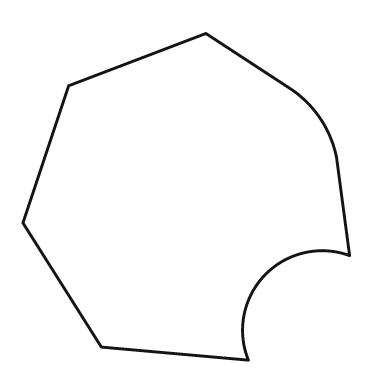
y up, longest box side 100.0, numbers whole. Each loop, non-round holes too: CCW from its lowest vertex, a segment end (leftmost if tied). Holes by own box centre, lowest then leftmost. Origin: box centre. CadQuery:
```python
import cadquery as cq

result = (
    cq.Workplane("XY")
    .moveTo(19.0, -50.0)
    .threePointArc((24.0, -24.0), (50.0, -18.0))
    .lineTo(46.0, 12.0)
    .threePointArc((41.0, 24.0), (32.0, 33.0))
    .lineTo(6.0, 50.0)
    .lineTo(-36.0, 34.0)
    .lineTo(-50.0, -8.0)
    .lineTo(-26.0, -46.0)
    .close()
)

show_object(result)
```